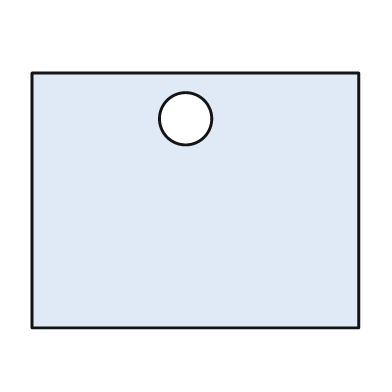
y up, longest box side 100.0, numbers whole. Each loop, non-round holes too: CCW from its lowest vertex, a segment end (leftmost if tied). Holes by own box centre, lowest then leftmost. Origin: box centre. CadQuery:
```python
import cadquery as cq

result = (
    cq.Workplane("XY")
    .moveTo(-50.0, -39.0)
    .lineTo(50.0, -39.0)
    .lineTo(50.0, 39.0)
    .lineTo(-50.0, 39.0)
    .close()
    .moveTo(-3.0, 25.0)
    .circle(8.0)
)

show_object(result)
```